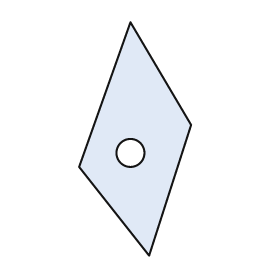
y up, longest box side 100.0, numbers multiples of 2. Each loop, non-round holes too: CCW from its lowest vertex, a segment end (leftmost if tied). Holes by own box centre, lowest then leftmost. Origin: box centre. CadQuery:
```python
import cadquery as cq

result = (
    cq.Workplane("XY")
    .moveTo(6.0, -50.0)
    .lineTo(24.0, 6.0)
    .lineTo(-2.0, 50.0)
    .lineTo(-24.0, -12.0)
    .close()
    .moveTo(-2.0, -6.0)
    .circle(6.0)
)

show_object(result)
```